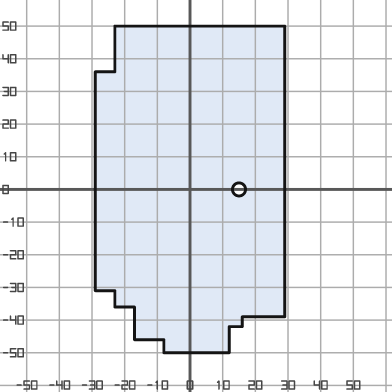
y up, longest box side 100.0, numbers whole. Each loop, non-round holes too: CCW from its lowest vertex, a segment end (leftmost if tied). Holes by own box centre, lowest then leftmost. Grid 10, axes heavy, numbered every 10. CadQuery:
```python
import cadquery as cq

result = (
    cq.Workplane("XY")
    .moveTo(-8.0, -50.0)
    .lineTo(12.0, -50.0)
    .lineTo(12.0, -42.0)
    .lineTo(16.0, -42.0)
    .lineTo(16.0, -39.0)
    .lineTo(29.0, -39.0)
    .lineTo(29.0, 50.0)
    .lineTo(-23.0, 50.0)
    .lineTo(-23.0, 36.0)
    .lineTo(-29.0, 36.0)
    .lineTo(-29.0, -31.0)
    .lineTo(-23.0, -31.0)
    .lineTo(-23.0, -36.0)
    .lineTo(-17.0, -36.0)
    .lineTo(-17.0, -46.0)
    .lineTo(-8.0, -46.0)
    .close()
    .moveTo(15.0, 0.0)
    .circle(2.0)
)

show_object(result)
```